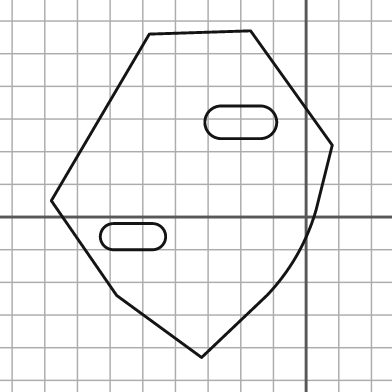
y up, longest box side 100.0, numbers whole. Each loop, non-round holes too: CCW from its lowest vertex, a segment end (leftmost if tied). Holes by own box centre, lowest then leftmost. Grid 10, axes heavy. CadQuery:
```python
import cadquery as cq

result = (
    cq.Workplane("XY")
    .moveTo(-32.0, -43.0)
    .lineTo(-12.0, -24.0)
    .threePointArc((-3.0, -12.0), (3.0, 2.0))
    .lineTo(8.0, 22.0)
    .lineTo(-17.0, 57.0)
    .lineTo(-48.0, 56.0)
    .lineTo(-78.0, 5.0)
    .lineTo(-58.0, -24.0)
    .close()
    .moveTo(-59.0, -10.0)
    .lineTo(-47.0, -10.0)
    .threePointArc((-43.0, -6.0), (-47.0, -2.0))
    .lineTo(-59.0, -2.0)
    .threePointArc((-63.0, -6.0), (-59.0, -10.0))
    .close()
    .moveTo(-26.0, 24.0)
    .lineTo(-14.0, 24.0)
    .threePointArc((-9.0, 29.0), (-14.0, 34.0))
    .lineTo(-26.0, 34.0)
    .threePointArc((-31.0, 29.0), (-26.0, 24.0))
    .close()
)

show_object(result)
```